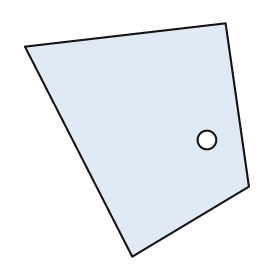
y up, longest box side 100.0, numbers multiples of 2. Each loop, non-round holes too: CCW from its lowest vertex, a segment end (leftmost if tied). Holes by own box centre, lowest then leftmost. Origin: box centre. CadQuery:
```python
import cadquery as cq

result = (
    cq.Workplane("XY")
    .moveTo(-2.0, -50.0)
    .lineTo(48.0, -20.0)
    .lineTo(38.0, 50.0)
    .lineTo(-48.0, 40.0)
    .close()
    .moveTo(30.0, 0.0)
    .circle(4.0)
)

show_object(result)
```